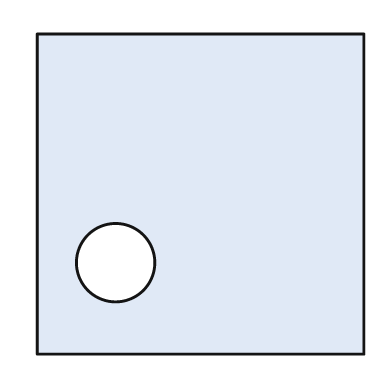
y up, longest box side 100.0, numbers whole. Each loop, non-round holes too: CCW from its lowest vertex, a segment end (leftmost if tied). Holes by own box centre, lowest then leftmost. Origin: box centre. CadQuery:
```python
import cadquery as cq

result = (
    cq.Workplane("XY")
    .moveTo(-50.0, -49.0)
    .lineTo(50.0, -49.0)
    .lineTo(50.0, 49.0)
    .lineTo(-50.0, 49.0)
    .close()
    .moveTo(-26.0, -21.0)
    .circle(12.0)
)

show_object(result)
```